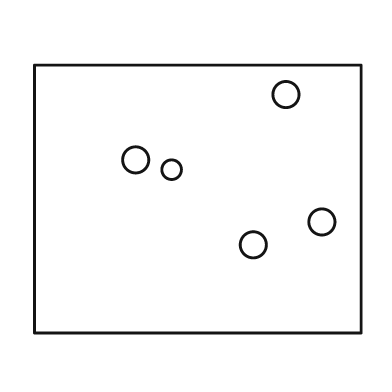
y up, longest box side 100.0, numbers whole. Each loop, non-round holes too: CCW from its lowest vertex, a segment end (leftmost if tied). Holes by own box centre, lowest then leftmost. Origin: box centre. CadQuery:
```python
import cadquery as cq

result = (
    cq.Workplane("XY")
    .moveTo(-50.0, -41.0)
    .lineTo(50.0, -41.0)
    .lineTo(50.0, 41.0)
    .lineTo(-50.0, 41.0)
    .close()
    .moveTo(17.0, -14.0)
    .circle(4.0)
    .moveTo(38.0, -7.0)
    .circle(4.0)
    .moveTo(-8.0, 9.0)
    .circle(3.0)
    .moveTo(-19.0, 12.0)
    .circle(4.0)
    .moveTo(27.0, 32.0)
    .circle(4.0)
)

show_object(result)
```